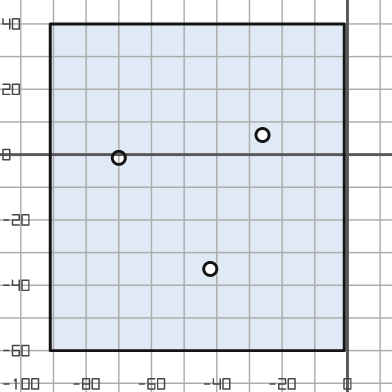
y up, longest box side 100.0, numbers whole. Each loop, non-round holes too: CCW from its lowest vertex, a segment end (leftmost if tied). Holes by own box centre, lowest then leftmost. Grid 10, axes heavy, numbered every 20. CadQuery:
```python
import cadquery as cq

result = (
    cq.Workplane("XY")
    .moveTo(-91.0, -60.0)
    .lineTo(-1.0, -60.0)
    .lineTo(-1.0, 40.0)
    .lineTo(-91.0, 40.0)
    .close()
    .moveTo(-42.0, -35.0)
    .circle(2.0)
    .moveTo(-70.0, -1.0)
    .circle(2.0)
    .moveTo(-26.0, 6.0)
    .circle(2.0)
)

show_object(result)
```